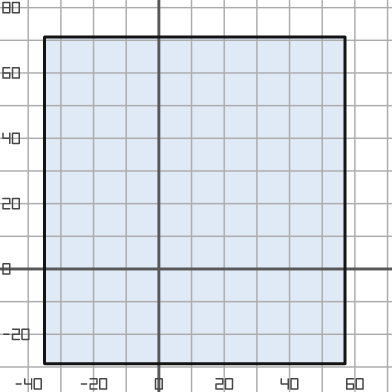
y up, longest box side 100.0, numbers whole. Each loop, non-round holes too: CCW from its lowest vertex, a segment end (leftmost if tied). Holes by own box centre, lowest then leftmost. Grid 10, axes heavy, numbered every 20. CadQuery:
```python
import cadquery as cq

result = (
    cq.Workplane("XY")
    .moveTo(-35.0, -29.0)
    .lineTo(57.0, -29.0)
    .lineTo(57.0, 71.0)
    .lineTo(-35.0, 71.0)
    .close()
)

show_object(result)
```